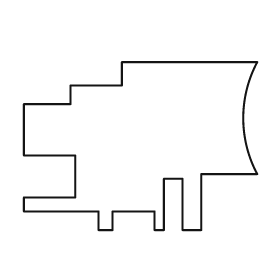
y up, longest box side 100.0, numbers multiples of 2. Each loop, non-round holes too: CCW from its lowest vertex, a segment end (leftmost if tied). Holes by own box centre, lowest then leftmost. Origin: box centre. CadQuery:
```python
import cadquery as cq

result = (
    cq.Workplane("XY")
    .moveTo(-18.0, -36.0)
    .lineTo(-12.0, -36.0)
    .lineTo(-12.0, -28.0)
    .lineTo(6.0, -28.0)
    .lineTo(6.0, -36.0)
    .lineTo(10.0, -36.0)
    .lineTo(10.0, -14.0)
    .lineTo(18.0, -14.0)
    .lineTo(18.0, -36.0)
    .lineTo(26.0, -36.0)
    .lineTo(26.0, -12.0)
    .lineTo(50.0, -12.0)
    .threePointArc((44.0, 12.0), (50.0, 36.0))
    .lineTo(-8.0, 36.0)
    .lineTo(-8.0, 26.0)
    .lineTo(-30.0, 26.0)
    .lineTo(-30.0, 18.0)
    .lineTo(-50.0, 18.0)
    .lineTo(-50.0, -4.0)
    .lineTo(-28.0, -4.0)
    .lineTo(-28.0, -22.0)
    .lineTo(-50.0, -22.0)
    .lineTo(-50.0, -28.0)
    .lineTo(-18.0, -28.0)
    .close()
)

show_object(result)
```